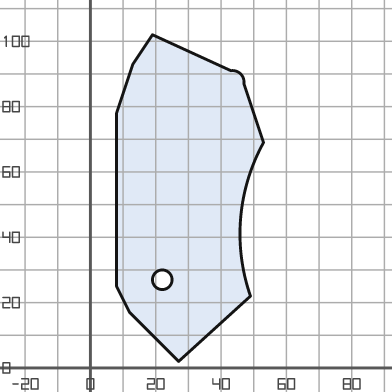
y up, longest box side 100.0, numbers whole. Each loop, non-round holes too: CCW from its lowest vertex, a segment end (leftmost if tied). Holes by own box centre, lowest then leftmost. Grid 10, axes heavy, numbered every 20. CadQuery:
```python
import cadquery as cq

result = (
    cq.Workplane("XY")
    .moveTo(27.0, 2.0)
    .lineTo(49.0, 22.0)
    .threePointArc((46.0, 46.0), (53.0, 69.0))
    .lineTo(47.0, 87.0)
    .threePointArc((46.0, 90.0), (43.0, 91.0))
    .lineTo(19.0, 102.0)
    .lineTo(13.0, 93.0)
    .lineTo(8.0, 78.0)
    .lineTo(8.0, 25.0)
    .lineTo(12.0, 17.0)
    .close()
    .moveTo(22.0, 27.0)
    .circle(3.0)
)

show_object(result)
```